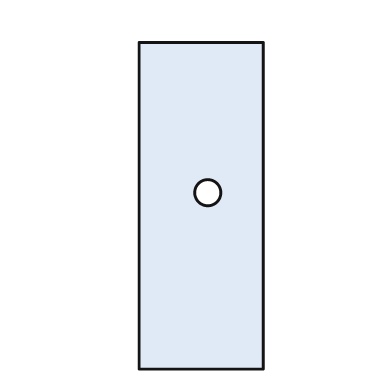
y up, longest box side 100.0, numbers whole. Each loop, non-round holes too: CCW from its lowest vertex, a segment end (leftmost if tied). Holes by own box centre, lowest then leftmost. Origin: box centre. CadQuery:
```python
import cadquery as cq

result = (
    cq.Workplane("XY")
    .moveTo(-19.0, -50.0)
    .lineTo(19.0, -50.0)
    .lineTo(19.0, 50.0)
    .lineTo(-19.0, 50.0)
    .close()
    .moveTo(2.0, 4.0)
    .circle(4.0)
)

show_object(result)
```